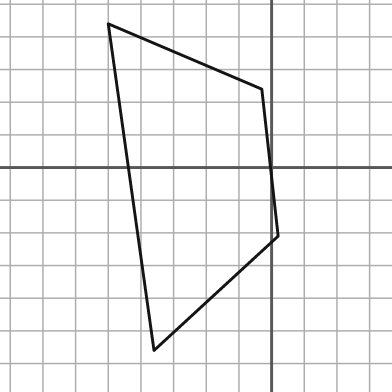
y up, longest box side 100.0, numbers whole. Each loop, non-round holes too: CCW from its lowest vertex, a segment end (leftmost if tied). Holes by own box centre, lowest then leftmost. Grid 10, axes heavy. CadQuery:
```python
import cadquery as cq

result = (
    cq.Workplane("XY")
    .moveTo(-36.0, -56.0)
    .lineTo(2.0, -21.0)
    .lineTo(-3.0, 24.0)
    .lineTo(-50.0, 44.0)
    .close()
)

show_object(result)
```